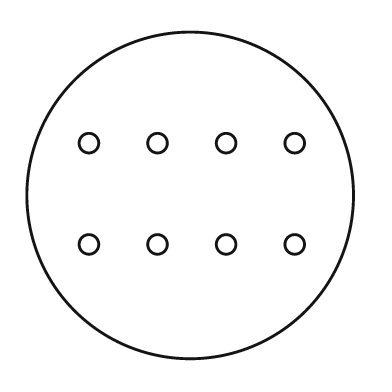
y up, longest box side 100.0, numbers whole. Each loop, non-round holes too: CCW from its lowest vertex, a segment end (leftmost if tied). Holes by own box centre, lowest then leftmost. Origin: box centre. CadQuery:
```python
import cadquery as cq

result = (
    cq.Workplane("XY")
    .moveTo(0.0, 0.0)
    .circle(50.0)
    .moveTo(-31.0, -15.0)
    .circle(3.0)
    .moveTo(-10.0, -15.0)
    .circle(3.0)
    .moveTo(11.0, -15.0)
    .circle(3.0)
    .moveTo(32.0, -15.0)
    .circle(3.0)
    .moveTo(-31.0, 16.0)
    .circle(3.0)
    .moveTo(-10.0, 16.0)
    .circle(3.0)
    .moveTo(11.0, 16.0)
    .circle(3.0)
    .moveTo(32.0, 16.0)
    .circle(3.0)
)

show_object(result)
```